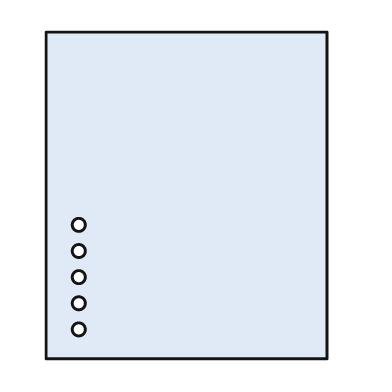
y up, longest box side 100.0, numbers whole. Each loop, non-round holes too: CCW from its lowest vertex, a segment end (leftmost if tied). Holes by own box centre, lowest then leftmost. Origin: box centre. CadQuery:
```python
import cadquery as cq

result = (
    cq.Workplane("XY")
    .moveTo(-43.0, -50.0)
    .lineTo(43.0, -50.0)
    .lineTo(43.0, 50.0)
    .lineTo(-43.0, 50.0)
    .close()
    .moveTo(-33.0, -41.0)
    .circle(2.0)
    .moveTo(-33.0, -33.0)
    .circle(2.0)
    .moveTo(-33.0, -25.0)
    .circle(2.0)
    .moveTo(-33.0, -17.0)
    .circle(2.0)
    .moveTo(-33.0, -9.0)
    .circle(2.0)
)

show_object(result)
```